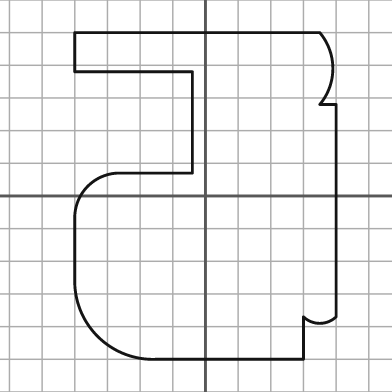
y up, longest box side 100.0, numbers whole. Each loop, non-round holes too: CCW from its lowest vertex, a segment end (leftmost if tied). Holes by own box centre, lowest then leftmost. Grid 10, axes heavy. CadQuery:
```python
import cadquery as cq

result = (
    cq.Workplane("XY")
    .moveTo(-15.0, -50.0)
    .lineTo(30.0, -50.0)
    .lineTo(30.0, -37.0)
    .threePointArc((35.0, -39.0), (40.0, -37.0))
    .lineTo(40.0, 28.0)
    .lineTo(35.0, 28.0)
    .threePointArc((39.0, 39.0), (35.0, 50.0))
    .lineTo(-40.0, 50.0)
    .lineTo(-40.0, 38.0)
    .lineTo(-4.0, 38.0)
    .lineTo(-4.0, 7.0)
    .lineTo(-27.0, 7.0)
    .threePointArc((-36.0, 3.0), (-40.0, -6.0))
    .lineTo(-40.0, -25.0)
    .threePointArc((-33.0, -43.0), (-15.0, -50.0))
    .close()
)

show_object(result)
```